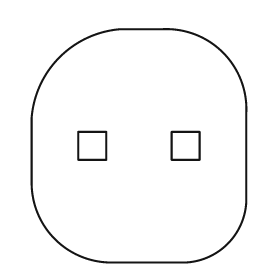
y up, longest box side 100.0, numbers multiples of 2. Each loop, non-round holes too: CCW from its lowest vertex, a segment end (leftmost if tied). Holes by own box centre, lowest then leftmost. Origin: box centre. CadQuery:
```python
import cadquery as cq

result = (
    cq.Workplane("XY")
    .moveTo(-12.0, -50.0)
    .lineTo(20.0, -50.0)
    .threePointArc((38.0, -42.0), (46.0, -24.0))
    .lineTo(46.0, 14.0)
    .threePointArc((36.0, 40.0), (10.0, 50.0))
    .lineTo(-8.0, 50.0)
    .threePointArc((-34.0, 38.0), (-46.0, 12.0))
    .lineTo(-46.0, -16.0)
    .threePointArc((-36.0, -40.0), (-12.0, -50.0))
    .close()
    .moveTo(-26.0, -6.0)
    .lineTo(-14.0, -6.0)
    .lineTo(-14.0, 6.0)
    .lineTo(-26.0, 6.0)
    .close()
    .moveTo(14.0, -6.0)
    .lineTo(26.0, -6.0)
    .lineTo(26.0, 6.0)
    .lineTo(14.0, 6.0)
    .close()
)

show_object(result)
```